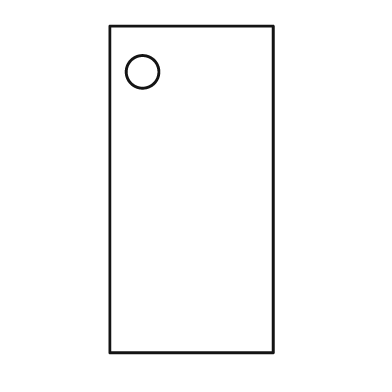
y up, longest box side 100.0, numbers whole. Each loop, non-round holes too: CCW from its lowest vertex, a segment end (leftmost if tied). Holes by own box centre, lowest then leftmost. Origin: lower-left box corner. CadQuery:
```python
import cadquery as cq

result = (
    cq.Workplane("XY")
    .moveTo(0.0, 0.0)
    .lineTo(50.0, 0.0)
    .lineTo(50.0, 100.0)
    .lineTo(0.0, 100.0)
    .close()
    .moveTo(10.0, 86.0)
    .circle(5.0)
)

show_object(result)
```